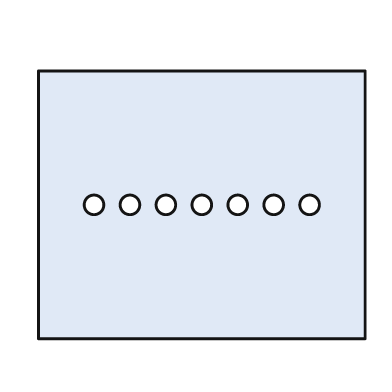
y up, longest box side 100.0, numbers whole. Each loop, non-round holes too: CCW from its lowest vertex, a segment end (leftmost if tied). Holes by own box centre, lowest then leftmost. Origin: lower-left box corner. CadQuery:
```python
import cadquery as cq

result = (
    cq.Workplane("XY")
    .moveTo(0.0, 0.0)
    .lineTo(100.0, 0.0)
    .lineTo(100.0, 82.0)
    .lineTo(0.0, 82.0)
    .close()
    .moveTo(17.0, 41.0)
    .circle(3.0)
    .moveTo(28.0, 41.0)
    .circle(3.0)
    .moveTo(39.0, 41.0)
    .circle(3.0)
    .moveTo(50.0, 41.0)
    .circle(3.0)
    .moveTo(61.0, 41.0)
    .circle(3.0)
    .moveTo(72.0, 41.0)
    .circle(3.0)
    .moveTo(83.0, 41.0)
    .circle(3.0)
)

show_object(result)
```